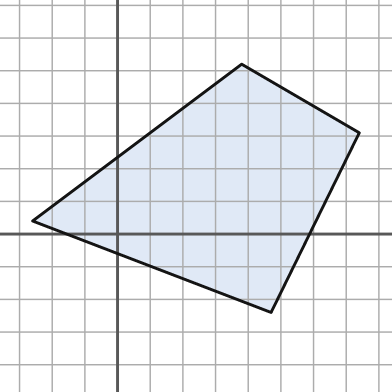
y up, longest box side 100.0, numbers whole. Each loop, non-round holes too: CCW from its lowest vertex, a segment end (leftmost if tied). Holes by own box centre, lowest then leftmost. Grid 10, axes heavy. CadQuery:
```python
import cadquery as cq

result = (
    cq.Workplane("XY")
    .moveTo(47.0, -24.0)
    .lineTo(74.0, 31.0)
    .lineTo(38.0, 52.0)
    .lineTo(-26.0, 4.0)
    .close()
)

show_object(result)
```